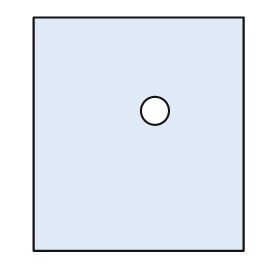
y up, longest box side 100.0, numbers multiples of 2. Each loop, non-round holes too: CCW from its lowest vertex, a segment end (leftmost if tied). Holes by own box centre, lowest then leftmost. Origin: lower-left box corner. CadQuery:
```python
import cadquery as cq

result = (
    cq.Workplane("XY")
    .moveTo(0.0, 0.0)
    .lineTo(90.0, 0.0)
    .lineTo(90.0, 100.0)
    .lineTo(0.0, 100.0)
    .close()
    .moveTo(52.0, 60.0)
    .circle(6.0)
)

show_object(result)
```